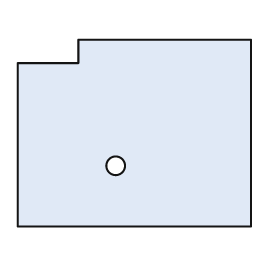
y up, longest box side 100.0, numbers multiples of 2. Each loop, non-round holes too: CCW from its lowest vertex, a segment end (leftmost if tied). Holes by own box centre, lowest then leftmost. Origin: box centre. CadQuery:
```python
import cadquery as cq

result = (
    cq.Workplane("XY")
    .moveTo(-50.0, -40.0)
    .lineTo(50.0, -40.0)
    .lineTo(50.0, 40.0)
    .lineTo(-24.0, 40.0)
    .lineTo(-24.0, 30.0)
    .lineTo(-50.0, 30.0)
    .close()
    .moveTo(-8.0, -14.0)
    .circle(4.0)
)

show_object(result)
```